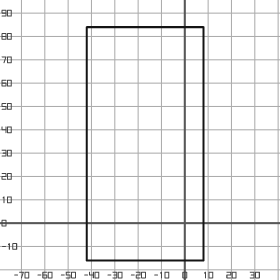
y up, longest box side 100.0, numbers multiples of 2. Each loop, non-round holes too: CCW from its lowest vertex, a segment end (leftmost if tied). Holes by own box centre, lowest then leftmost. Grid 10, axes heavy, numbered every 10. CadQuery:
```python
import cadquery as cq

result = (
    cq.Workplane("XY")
    .moveTo(-42.0, -16.0)
    .lineTo(8.0, -16.0)
    .lineTo(8.0, 84.0)
    .lineTo(-42.0, 84.0)
    .close()
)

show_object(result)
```